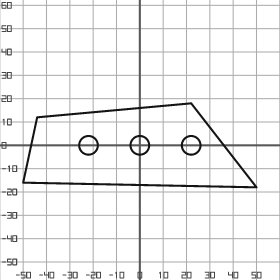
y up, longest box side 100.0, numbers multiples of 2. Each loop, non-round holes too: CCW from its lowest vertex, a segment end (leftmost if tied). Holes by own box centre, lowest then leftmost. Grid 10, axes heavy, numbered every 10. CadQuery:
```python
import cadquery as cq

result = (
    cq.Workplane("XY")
    .moveTo(50.0, -18.0)
    .lineTo(22.0, 18.0)
    .lineTo(-44.0, 12.0)
    .lineTo(-50.0, -16.0)
    .close()
    .moveTo(-22.0, 0.0)
    .circle(4.0)
    .moveTo(0.0, 0.0)
    .circle(4.0)
    .moveTo(22.0, 0.0)
    .circle(4.0)
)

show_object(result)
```